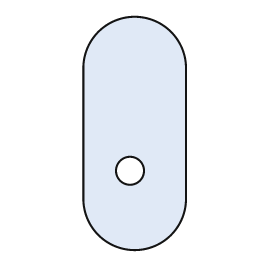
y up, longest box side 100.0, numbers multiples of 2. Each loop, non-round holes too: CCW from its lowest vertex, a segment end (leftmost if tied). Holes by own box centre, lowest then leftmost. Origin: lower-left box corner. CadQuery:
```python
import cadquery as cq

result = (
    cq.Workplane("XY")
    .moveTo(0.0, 22.0)
    .threePointArc((22.0, 0.0), (44.0, 22.0))
    .lineTo(44.0, 78.0)
    .threePointArc((22.0, 100.0), (0.0, 78.0))
    .close()
    .moveTo(20.0, 34.0)
    .circle(6.0)
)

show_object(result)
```